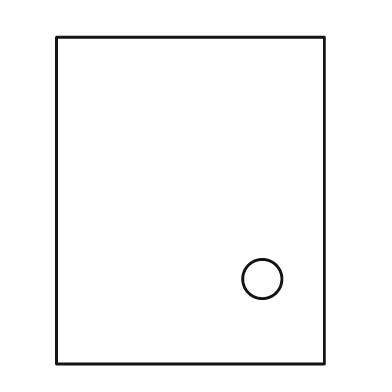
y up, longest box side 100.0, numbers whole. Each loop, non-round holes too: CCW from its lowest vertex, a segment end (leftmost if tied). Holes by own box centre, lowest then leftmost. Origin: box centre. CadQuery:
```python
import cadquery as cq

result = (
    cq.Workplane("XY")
    .moveTo(-41.0, -50.0)
    .lineTo(41.0, -50.0)
    .lineTo(41.0, 50.0)
    .lineTo(-41.0, 50.0)
    .close()
    .moveTo(22.0, -24.0)
    .circle(6.0)
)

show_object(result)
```